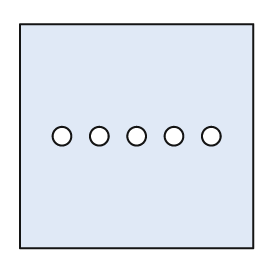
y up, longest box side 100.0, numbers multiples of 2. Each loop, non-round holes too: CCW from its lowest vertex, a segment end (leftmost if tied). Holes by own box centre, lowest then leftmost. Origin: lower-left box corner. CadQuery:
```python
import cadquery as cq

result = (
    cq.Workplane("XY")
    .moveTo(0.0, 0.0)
    .lineTo(100.0, 0.0)
    .lineTo(100.0, 96.0)
    .lineTo(0.0, 96.0)
    .close()
    .moveTo(18.0, 48.0)
    .circle(4.0)
    .moveTo(34.0, 48.0)
    .circle(4.0)
    .moveTo(50.0, 48.0)
    .circle(4.0)
    .moveTo(66.0, 48.0)
    .circle(4.0)
    .moveTo(82.0, 48.0)
    .circle(4.0)
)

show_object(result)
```